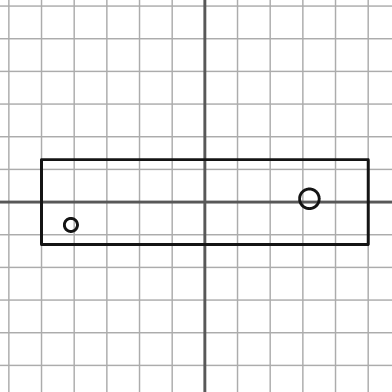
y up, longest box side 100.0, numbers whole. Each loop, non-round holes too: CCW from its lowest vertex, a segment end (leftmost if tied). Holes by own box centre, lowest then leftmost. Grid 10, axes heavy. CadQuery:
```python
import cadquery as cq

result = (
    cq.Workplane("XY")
    .moveTo(-50.0, -13.0)
    .lineTo(50.0, -13.0)
    .lineTo(50.0, 13.0)
    .lineTo(-50.0, 13.0)
    .close()
    .moveTo(-41.0, -7.0)
    .circle(2.0)
    .moveTo(32.0, 1.0)
    .circle(3.0)
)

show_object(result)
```